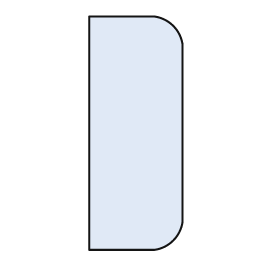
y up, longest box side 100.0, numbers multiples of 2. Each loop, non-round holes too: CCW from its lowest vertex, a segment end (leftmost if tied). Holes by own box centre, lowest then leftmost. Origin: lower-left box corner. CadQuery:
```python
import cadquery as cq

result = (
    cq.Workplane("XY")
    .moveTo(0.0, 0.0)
    .lineTo(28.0, 0.0)
    .threePointArc((36.0, 4.0), (40.0, 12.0))
    .lineTo(40.0, 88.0)
    .threePointArc((36.0, 96.0), (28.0, 100.0))
    .lineTo(0.0, 100.0)
    .close()
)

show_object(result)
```